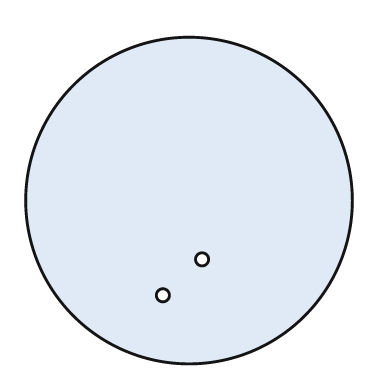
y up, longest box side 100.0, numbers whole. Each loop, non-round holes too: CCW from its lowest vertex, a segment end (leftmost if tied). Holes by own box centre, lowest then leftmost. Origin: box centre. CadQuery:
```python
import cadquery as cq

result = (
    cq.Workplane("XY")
    .moveTo(0.0, 0.0)
    .circle(50.0)
    .moveTo(-8.0, -29.0)
    .circle(2.0)
    .moveTo(4.0, -18.0)
    .circle(2.0)
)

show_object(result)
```